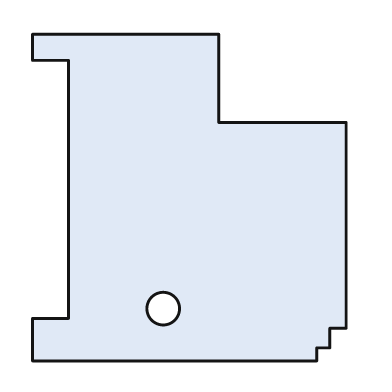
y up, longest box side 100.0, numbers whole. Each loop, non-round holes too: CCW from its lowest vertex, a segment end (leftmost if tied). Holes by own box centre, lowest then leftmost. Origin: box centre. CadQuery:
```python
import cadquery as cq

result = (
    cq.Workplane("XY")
    .moveTo(-48.0, -50.0)
    .lineTo(39.0, -50.0)
    .lineTo(39.0, -46.0)
    .lineTo(43.0, -46.0)
    .lineTo(43.0, -40.0)
    .lineTo(48.0, -40.0)
    .lineTo(48.0, 23.0)
    .lineTo(9.0, 23.0)
    .lineTo(9.0, 50.0)
    .lineTo(-48.0, 50.0)
    .lineTo(-48.0, 42.0)
    .lineTo(-37.0, 42.0)
    .lineTo(-37.0, -37.0)
    .lineTo(-48.0, -37.0)
    .close()
    .moveTo(-8.0, -34.0)
    .circle(5.0)
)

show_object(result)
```